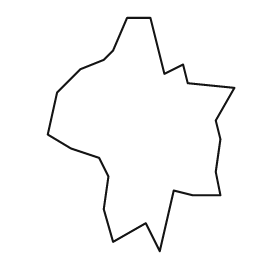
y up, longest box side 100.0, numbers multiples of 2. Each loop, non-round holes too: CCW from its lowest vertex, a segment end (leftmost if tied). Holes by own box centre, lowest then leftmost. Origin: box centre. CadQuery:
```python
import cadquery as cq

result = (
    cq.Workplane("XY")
    .moveTo(8.0, -50.0)
    .lineTo(14.0, -24.0)
    .lineTo(22.0, -26.0)
    .lineTo(34.0, -26.0)
    .lineTo(32.0, -16.0)
    .lineTo(34.0, -2.0)
    .lineTo(32.0, 6.0)
    .lineTo(40.0, 20.0)
    .lineTo(20.0, 22.0)
    .lineTo(18.0, 30.0)
    .lineTo(10.0, 26.0)
    .lineTo(4.0, 50.0)
    .lineTo(-6.0, 50.0)
    .lineTo(-12.0, 36.0)
    .lineTo(-16.0, 32.0)
    .lineTo(-26.0, 28.0)
    .lineTo(-36.0, 18.0)
    .lineTo(-40.0, 0.0)
    .lineTo(-30.0, -6.0)
    .lineTo(-18.0, -10.0)
    .lineTo(-14.0, -18.0)
    .lineTo(-16.0, -32.0)
    .lineTo(-12.0, -46.0)
    .lineTo(2.0, -38.0)
    .close()
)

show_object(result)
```